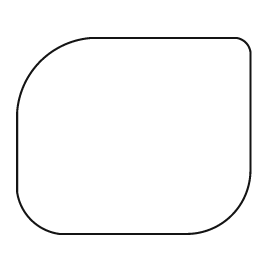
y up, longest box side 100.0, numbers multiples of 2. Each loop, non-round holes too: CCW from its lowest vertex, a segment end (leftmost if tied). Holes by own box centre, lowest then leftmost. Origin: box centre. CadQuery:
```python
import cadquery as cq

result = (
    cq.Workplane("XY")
    .moveTo(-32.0, -42.0)
    .lineTo(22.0, -42.0)
    .threePointArc((42.0, -34.0), (50.0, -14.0))
    .lineTo(50.0, 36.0)
    .threePointArc((48.0, 40.0), (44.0, 42.0))
    .lineTo(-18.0, 42.0)
    .threePointArc((-40.0, 32.0), (-50.0, 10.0))
    .lineTo(-50.0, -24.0)
    .threePointArc((-44.0, -36.0), (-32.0, -42.0))
    .close()
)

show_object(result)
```